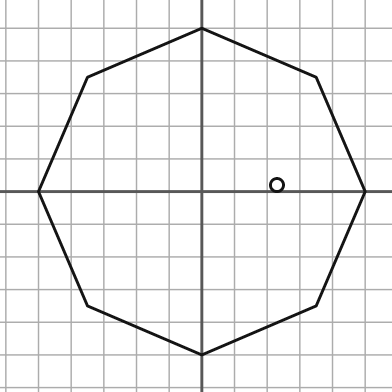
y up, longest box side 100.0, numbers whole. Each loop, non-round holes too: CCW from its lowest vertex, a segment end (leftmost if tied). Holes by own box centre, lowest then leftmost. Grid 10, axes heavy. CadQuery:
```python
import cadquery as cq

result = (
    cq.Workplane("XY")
    .moveTo(0.0, -50.0)
    .lineTo(35.0, -35.0)
    .lineTo(50.0, 0.0)
    .lineTo(35.0, 35.0)
    .lineTo(0.0, 50.0)
    .lineTo(-35.0, 35.0)
    .lineTo(-50.0, 0.0)
    .lineTo(-35.0, -35.0)
    .close()
    .moveTo(23.0, 2.0)
    .circle(2.0)
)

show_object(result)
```